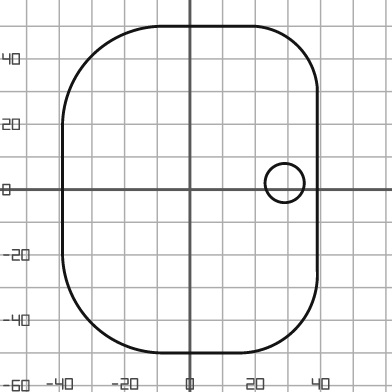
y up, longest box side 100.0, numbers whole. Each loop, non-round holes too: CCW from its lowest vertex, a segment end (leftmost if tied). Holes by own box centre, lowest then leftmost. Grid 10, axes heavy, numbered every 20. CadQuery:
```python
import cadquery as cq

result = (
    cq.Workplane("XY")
    .moveTo(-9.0, -50.0)
    .lineTo(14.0, -50.0)
    .threePointArc((32.0, -43.0), (39.0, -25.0))
    .lineTo(39.0, 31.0)
    .threePointArc((33.0, 44.0), (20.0, 50.0))
    .lineTo(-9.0, 50.0)
    .threePointArc((-30.0, 41.0), (-39.0, 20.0))
    .lineTo(-39.0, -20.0)
    .threePointArc((-30.0, -41.0), (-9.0, -50.0))
    .close()
    .moveTo(29.0, 2.0)
    .circle(6.0)
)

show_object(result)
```